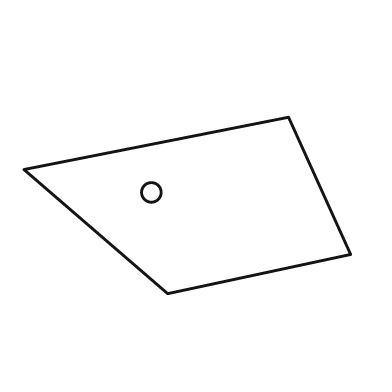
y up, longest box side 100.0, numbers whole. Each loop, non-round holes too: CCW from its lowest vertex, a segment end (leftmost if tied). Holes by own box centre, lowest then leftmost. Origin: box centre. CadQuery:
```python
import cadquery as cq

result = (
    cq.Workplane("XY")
    .moveTo(-6.0, -27.0)
    .lineTo(50.0, -15.0)
    .lineTo(31.0, 27.0)
    .lineTo(-50.0, 11.0)
    .close()
    .moveTo(-11.0, 4.0)
    .circle(3.0)
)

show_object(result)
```